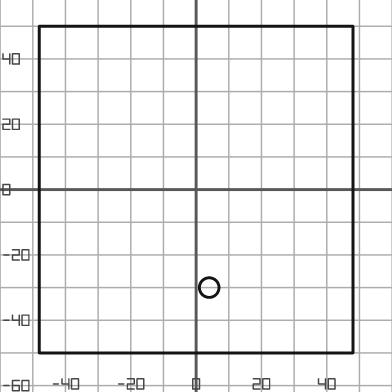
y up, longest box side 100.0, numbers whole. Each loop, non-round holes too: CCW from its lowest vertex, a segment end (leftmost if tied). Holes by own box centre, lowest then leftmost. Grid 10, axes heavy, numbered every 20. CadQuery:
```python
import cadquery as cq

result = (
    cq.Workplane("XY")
    .moveTo(-48.0, -50.0)
    .lineTo(48.0, -50.0)
    .lineTo(48.0, 50.0)
    .lineTo(-48.0, 50.0)
    .close()
    .moveTo(4.0, -30.0)
    .circle(3.0)
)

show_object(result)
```